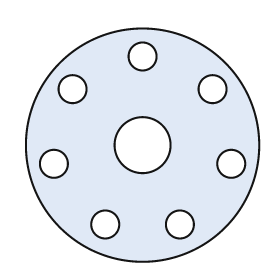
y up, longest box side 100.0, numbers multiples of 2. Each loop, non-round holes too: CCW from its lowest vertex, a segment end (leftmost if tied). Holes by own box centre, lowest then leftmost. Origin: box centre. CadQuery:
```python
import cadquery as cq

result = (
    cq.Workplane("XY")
    .moveTo(0.0, 0.0)
    .circle(50.0)
    .moveTo(-16.0, -34.0)
    .circle(6.0)
    .moveTo(16.0, -34.0)
    .circle(6.0)
    .moveTo(-38.0, -8.0)
    .circle(6.0)
    .moveTo(38.0, -8.0)
    .circle(6.0)
    .moveTo(0.0, 0.0)
    .circle(12.0)
    .moveTo(-30.0, 24.0)
    .circle(6.0)
    .moveTo(30.0, 24.0)
    .circle(6.0)
    .moveTo(0.0, 38.0)
    .circle(6.0)
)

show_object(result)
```